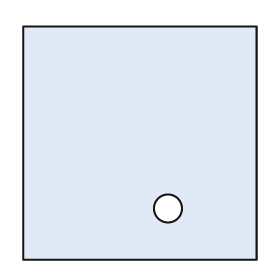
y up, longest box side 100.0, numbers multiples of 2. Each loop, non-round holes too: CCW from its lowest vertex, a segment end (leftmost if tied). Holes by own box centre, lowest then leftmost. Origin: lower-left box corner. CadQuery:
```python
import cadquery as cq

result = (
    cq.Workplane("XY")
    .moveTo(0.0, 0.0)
    .lineTo(100.0, 0.0)
    .lineTo(100.0, 100.0)
    .lineTo(0.0, 100.0)
    .close()
    .moveTo(62.0, 22.0)
    .circle(6.0)
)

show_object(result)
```